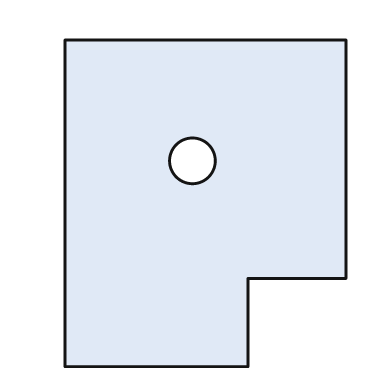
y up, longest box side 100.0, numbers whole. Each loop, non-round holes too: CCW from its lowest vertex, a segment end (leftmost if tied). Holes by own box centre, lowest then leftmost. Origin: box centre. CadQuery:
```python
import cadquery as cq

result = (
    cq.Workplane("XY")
    .moveTo(-43.0, -50.0)
    .lineTo(13.0, -50.0)
    .lineTo(13.0, -23.0)
    .lineTo(43.0, -23.0)
    .lineTo(43.0, 50.0)
    .lineTo(-43.0, 50.0)
    .close()
    .moveTo(-4.0, 13.0)
    .circle(7.0)
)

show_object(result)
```